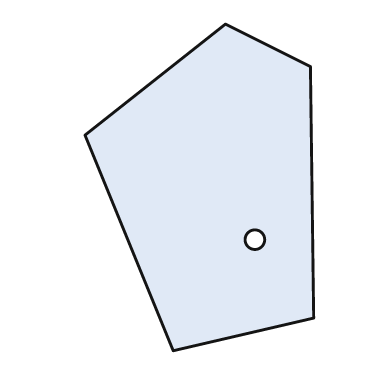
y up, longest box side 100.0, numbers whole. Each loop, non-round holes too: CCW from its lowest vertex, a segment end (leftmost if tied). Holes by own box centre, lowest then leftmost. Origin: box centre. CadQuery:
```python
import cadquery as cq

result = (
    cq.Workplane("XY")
    .moveTo(-8.0, -50.0)
    .lineTo(35.0, -40.0)
    .lineTo(34.0, 37.0)
    .lineTo(8.0, 50.0)
    .lineTo(-35.0, 16.0)
    .close()
    .moveTo(17.0, -16.0)
    .circle(3.0)
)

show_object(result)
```